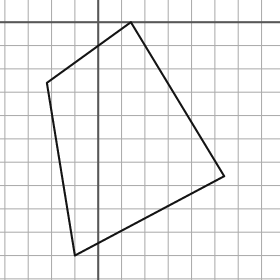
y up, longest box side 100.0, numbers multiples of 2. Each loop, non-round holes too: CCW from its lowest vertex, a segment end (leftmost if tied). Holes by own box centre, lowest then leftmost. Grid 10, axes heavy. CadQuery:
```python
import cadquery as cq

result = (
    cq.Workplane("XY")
    .moveTo(-10.0, -100.0)
    .lineTo(54.0, -66.0)
    .lineTo(14.0, 0.0)
    .lineTo(-22.0, -26.0)
    .close()
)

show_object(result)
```